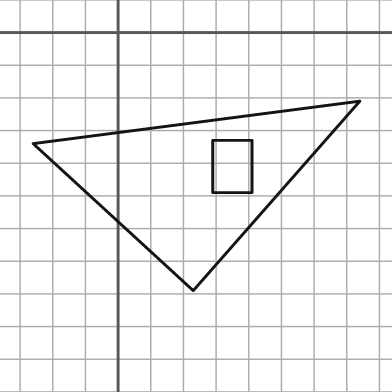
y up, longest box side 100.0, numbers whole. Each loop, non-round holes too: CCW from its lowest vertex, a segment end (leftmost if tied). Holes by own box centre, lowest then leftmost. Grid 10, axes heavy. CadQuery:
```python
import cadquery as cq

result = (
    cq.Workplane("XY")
    .moveTo(23.0, -79.0)
    .lineTo(74.0, -21.0)
    .lineTo(-26.0, -34.0)
    .close()
    .moveTo(29.0, -49.0)
    .lineTo(41.0, -49.0)
    .lineTo(41.0, -33.0)
    .lineTo(29.0, -33.0)
    .close()
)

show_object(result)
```